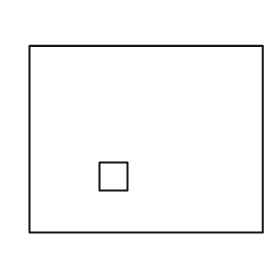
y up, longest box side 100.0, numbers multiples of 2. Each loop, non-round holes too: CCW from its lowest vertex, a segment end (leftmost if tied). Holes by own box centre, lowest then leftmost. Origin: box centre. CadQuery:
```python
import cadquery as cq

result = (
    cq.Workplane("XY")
    .moveTo(-50.0, -40.0)
    .lineTo(50.0, -40.0)
    .lineTo(50.0, 40.0)
    .lineTo(-50.0, 40.0)
    .close()
    .moveTo(-20.0, -22.0)
    .lineTo(-8.0, -22.0)
    .lineTo(-8.0, -10.0)
    .lineTo(-20.0, -10.0)
    .close()
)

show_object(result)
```